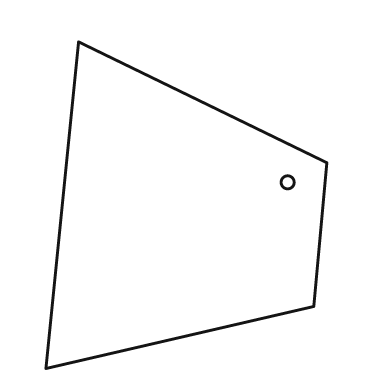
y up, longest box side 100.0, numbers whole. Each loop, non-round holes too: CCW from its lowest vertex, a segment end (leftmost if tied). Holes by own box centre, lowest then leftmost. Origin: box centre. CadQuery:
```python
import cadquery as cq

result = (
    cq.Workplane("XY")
    .moveTo(-43.0, -50.0)
    .lineTo(39.0, -31.0)
    .lineTo(43.0, 13.0)
    .lineTo(-33.0, 50.0)
    .close()
    .moveTo(31.0, 7.0)
    .circle(2.0)
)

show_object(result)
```